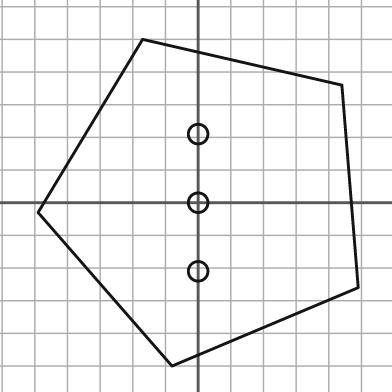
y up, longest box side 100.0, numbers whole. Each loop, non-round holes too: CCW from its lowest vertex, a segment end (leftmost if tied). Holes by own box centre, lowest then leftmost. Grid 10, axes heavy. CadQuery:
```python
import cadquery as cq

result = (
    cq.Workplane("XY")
    .moveTo(-8.0, -50.0)
    .lineTo(49.0, -26.0)
    .lineTo(44.0, 36.0)
    .lineTo(-17.0, 50.0)
    .lineTo(-49.0, -3.0)
    .close()
    .moveTo(0.0, -21.0)
    .circle(3.0)
    .moveTo(0.0, 0.0)
    .circle(3.0)
    .moveTo(0.0, 21.0)
    .circle(3.0)
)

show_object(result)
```